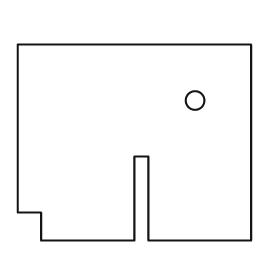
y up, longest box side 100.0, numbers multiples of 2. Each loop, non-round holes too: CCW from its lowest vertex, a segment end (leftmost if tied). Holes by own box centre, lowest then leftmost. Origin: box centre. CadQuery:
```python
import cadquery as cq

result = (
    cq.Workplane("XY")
    .moveTo(-40.0, -42.0)
    .lineTo(0.0, -42.0)
    .lineTo(0.0, -6.0)
    .lineTo(6.0, -6.0)
    .lineTo(6.0, -42.0)
    .lineTo(50.0, -42.0)
    .lineTo(50.0, 42.0)
    .lineTo(-50.0, 42.0)
    .lineTo(-50.0, -30.0)
    .lineTo(-40.0, -30.0)
    .close()
    .moveTo(26.0, 18.0)
    .circle(4.0)
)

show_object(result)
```